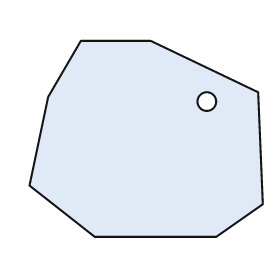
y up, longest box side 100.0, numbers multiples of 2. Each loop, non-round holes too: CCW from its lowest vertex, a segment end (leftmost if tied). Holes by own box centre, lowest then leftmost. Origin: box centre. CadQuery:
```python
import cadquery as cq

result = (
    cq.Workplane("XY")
    .moveTo(-22.0, -42.0)
    .lineTo(30.0, -42.0)
    .lineTo(50.0, -28.0)
    .lineTo(48.0, 20.0)
    .lineTo(2.0, 42.0)
    .lineTo(-28.0, 42.0)
    .lineTo(-42.0, 18.0)
    .lineTo(-50.0, -20.0)
    .close()
    .moveTo(26.0, 16.0)
    .circle(4.0)
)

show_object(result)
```